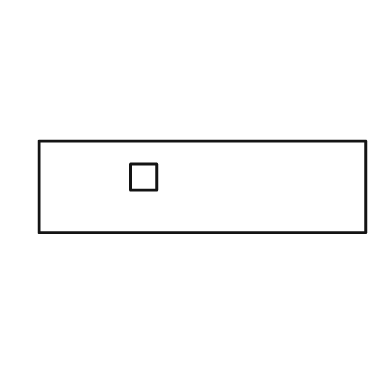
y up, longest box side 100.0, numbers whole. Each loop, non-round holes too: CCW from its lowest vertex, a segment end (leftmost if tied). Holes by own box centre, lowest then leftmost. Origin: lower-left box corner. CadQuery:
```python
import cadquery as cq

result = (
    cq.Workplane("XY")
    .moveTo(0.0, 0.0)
    .lineTo(100.0, 0.0)
    .lineTo(100.0, 28.0)
    .lineTo(0.0, 28.0)
    .close()
    .moveTo(28.0, 13.0)
    .lineTo(36.0, 13.0)
    .lineTo(36.0, 21.0)
    .lineTo(28.0, 21.0)
    .close()
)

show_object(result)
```